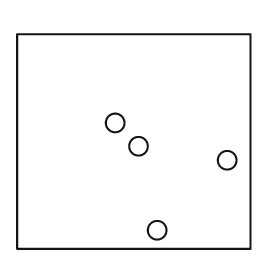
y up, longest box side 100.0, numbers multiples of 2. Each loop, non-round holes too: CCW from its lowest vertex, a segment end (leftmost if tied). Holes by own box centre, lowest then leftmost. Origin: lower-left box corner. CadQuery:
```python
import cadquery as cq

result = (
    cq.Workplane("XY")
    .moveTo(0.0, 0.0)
    .lineTo(100.0, 0.0)
    .lineTo(100.0, 92.0)
    .lineTo(0.0, 92.0)
    .close()
    .moveTo(60.0, 8.0)
    .circle(4.0)
    .moveTo(90.0, 38.0)
    .circle(4.0)
    .moveTo(52.0, 44.0)
    .circle(4.0)
    .moveTo(42.0, 54.0)
    .circle(4.0)
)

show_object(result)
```